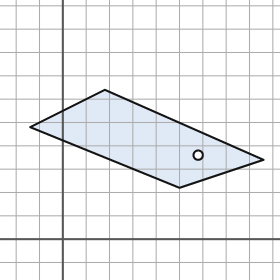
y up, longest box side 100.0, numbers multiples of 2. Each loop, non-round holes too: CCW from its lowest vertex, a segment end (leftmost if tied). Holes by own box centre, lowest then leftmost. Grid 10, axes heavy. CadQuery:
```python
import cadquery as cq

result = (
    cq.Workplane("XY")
    .moveTo(50.0, 22.0)
    .lineTo(86.0, 34.0)
    .lineTo(18.0, 64.0)
    .lineTo(-14.0, 48.0)
    .close()
    .moveTo(58.0, 36.0)
    .circle(2.0)
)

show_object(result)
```